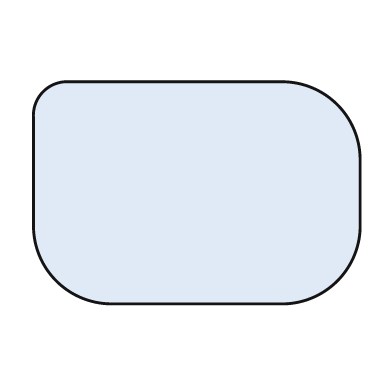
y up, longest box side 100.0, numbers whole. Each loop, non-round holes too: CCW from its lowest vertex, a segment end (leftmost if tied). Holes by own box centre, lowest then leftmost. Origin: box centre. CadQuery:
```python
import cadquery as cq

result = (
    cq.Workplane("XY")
    .moveTo(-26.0, -34.0)
    .lineTo(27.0, -34.0)
    .threePointArc((43.0, -27.0), (50.0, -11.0))
    .lineTo(50.0, 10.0)
    .threePointArc((43.0, 27.0), (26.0, 34.0))
    .lineTo(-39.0, 34.0)
    .threePointArc((-47.0, 31.0), (-50.0, 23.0))
    .lineTo(-50.0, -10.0)
    .threePointArc((-43.0, -27.0), (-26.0, -34.0))
    .close()
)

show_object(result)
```